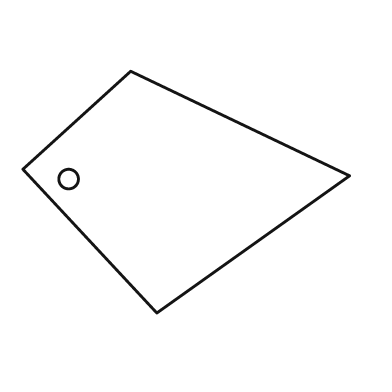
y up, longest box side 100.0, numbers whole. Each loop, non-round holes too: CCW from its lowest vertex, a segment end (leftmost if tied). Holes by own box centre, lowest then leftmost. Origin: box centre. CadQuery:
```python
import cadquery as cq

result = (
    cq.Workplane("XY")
    .moveTo(-9.0, -37.0)
    .lineTo(50.0, 5.0)
    .lineTo(-17.0, 37.0)
    .lineTo(-50.0, 7.0)
    .close()
    .moveTo(-36.0, 4.0)
    .circle(3.0)
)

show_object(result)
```